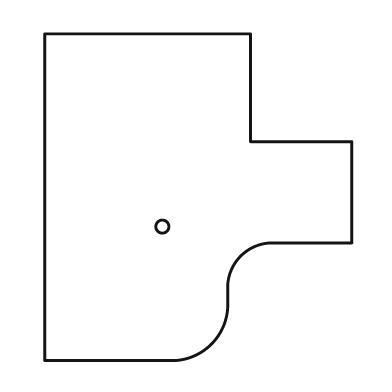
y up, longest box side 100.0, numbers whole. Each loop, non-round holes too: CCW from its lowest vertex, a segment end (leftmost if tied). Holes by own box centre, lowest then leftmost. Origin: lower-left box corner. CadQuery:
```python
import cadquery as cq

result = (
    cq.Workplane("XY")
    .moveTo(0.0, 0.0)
    .lineTo(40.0, 0.0)
    .threePointArc((51.0, 5.0), (56.0, 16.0))
    .lineTo(56.0, 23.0)
    .threePointArc((60.0, 32.0), (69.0, 36.0))
    .lineTo(94.0, 36.0)
    .lineTo(94.0, 67.0)
    .lineTo(63.0, 67.0)
    .lineTo(63.0, 100.0)
    .lineTo(0.0, 100.0)
    .close()
    .moveTo(36.0, 41.0)
    .circle(2.0)
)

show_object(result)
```